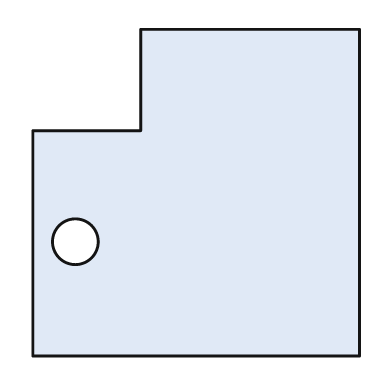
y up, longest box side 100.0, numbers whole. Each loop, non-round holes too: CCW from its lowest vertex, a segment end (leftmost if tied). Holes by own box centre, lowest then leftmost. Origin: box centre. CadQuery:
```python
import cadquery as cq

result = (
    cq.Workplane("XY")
    .moveTo(-50.0, -50.0)
    .lineTo(50.0, -50.0)
    .lineTo(50.0, 50.0)
    .lineTo(-17.0, 50.0)
    .lineTo(-17.0, 19.0)
    .lineTo(-50.0, 19.0)
    .close()
    .moveTo(-37.0, -15.0)
    .circle(7.0)
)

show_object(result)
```